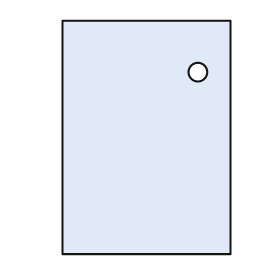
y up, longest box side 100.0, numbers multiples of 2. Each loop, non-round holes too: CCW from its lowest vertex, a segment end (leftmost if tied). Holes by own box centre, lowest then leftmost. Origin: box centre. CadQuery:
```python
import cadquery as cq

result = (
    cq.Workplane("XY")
    .moveTo(-36.0, -50.0)
    .lineTo(36.0, -50.0)
    .lineTo(36.0, 50.0)
    .lineTo(-36.0, 50.0)
    .close()
    .moveTo(22.0, 28.0)
    .circle(4.0)
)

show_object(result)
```